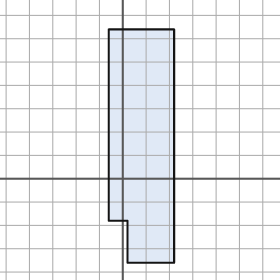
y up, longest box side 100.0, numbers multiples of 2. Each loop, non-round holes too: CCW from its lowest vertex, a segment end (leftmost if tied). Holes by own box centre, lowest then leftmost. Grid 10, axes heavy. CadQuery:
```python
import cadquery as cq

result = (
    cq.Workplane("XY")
    .moveTo(2.0, -36.0)
    .lineTo(22.0, -36.0)
    .lineTo(22.0, 64.0)
    .lineTo(-6.0, 64.0)
    .lineTo(-6.0, -18.0)
    .lineTo(2.0, -18.0)
    .close()
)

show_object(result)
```